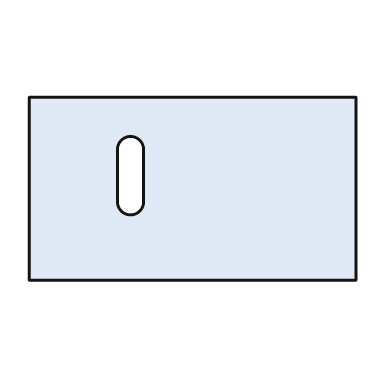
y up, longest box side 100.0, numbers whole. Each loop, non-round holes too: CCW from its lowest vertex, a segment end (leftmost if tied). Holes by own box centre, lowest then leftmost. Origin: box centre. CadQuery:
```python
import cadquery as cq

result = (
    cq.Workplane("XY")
    .moveTo(-50.0, -28.0)
    .lineTo(50.0, -28.0)
    .lineTo(50.0, 28.0)
    .lineTo(-50.0, 28.0)
    .close()
    .moveTo(-23.0, -4.0)
    .threePointArc((-19.0, -8.0), (-15.0, -4.0))
    .lineTo(-15.0, 12.0)
    .threePointArc((-19.0, 16.0), (-23.0, 12.0))
    .close()
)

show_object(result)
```